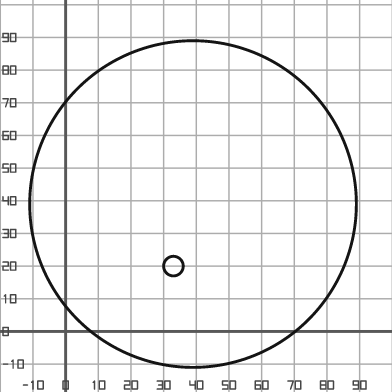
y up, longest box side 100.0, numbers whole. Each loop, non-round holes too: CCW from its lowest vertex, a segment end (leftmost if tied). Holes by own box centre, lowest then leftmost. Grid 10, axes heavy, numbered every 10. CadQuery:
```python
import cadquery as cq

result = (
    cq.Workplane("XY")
    .moveTo(39.0, 39.0)
    .circle(50.0)
    .moveTo(33.0, 20.0)
    .circle(3.0)
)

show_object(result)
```